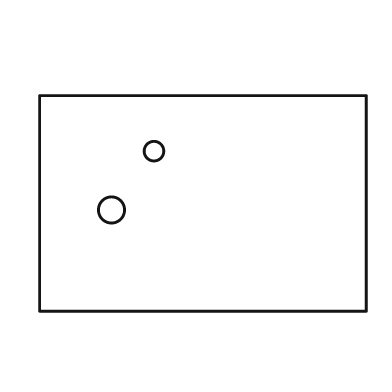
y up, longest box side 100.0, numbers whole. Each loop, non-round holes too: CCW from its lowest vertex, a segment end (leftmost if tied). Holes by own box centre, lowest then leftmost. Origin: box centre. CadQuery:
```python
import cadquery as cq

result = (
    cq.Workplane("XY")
    .moveTo(-50.0, -33.0)
    .lineTo(50.0, -33.0)
    .lineTo(50.0, 33.0)
    .lineTo(-50.0, 33.0)
    .close()
    .moveTo(-28.0, -2.0)
    .circle(4.0)
    .moveTo(-15.0, 16.0)
    .circle(3.0)
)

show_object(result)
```